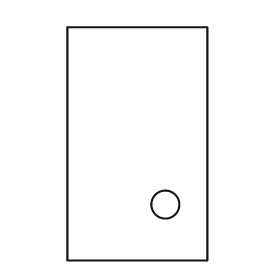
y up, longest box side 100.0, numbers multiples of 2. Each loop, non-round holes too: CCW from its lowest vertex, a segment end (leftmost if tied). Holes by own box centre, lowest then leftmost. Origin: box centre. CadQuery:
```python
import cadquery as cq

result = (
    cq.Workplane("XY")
    .moveTo(-30.0, -50.0)
    .lineTo(30.0, -50.0)
    .lineTo(30.0, 50.0)
    .lineTo(-30.0, 50.0)
    .close()
    .moveTo(12.0, -26.0)
    .circle(6.0)
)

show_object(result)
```